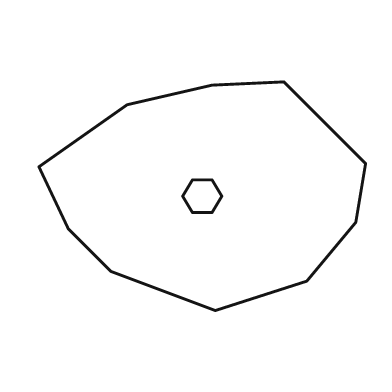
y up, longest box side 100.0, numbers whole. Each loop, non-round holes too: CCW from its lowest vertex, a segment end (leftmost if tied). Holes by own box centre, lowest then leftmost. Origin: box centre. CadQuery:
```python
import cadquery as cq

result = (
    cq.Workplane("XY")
    .moveTo(4.0, -35.0)
    .lineTo(32.0, -26.0)
    .lineTo(47.0, -8.0)
    .lineTo(50.0, 10.0)
    .lineTo(25.0, 35.0)
    .lineTo(3.0, 34.0)
    .lineTo(-23.0, 28.0)
    .lineTo(-50.0, 9.0)
    .lineTo(-41.0, -10.0)
    .lineTo(-28.0, -23.0)
    .close()
    .moveTo(-3.0, -5.0)
    .lineTo(3.0, -5.0)
    .lineTo(6.0, 0.0)
    .lineTo(3.0, 5.0)
    .lineTo(-3.0, 5.0)
    .lineTo(-6.0, 0.0)
    .close()
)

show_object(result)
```